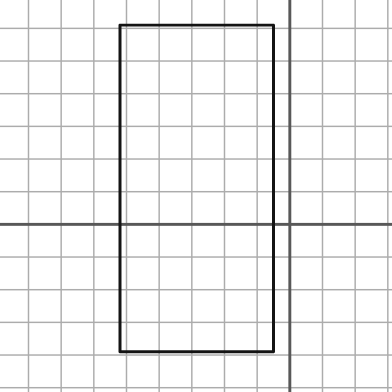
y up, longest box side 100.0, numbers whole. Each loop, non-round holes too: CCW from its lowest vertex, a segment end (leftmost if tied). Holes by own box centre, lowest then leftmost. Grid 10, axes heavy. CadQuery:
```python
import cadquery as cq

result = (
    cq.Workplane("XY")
    .moveTo(-52.0, -39.0)
    .lineTo(-5.0, -39.0)
    .lineTo(-5.0, 61.0)
    .lineTo(-52.0, 61.0)
    .close()
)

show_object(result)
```